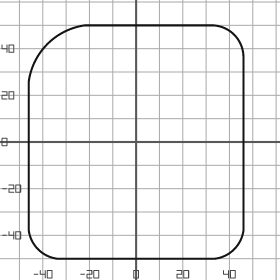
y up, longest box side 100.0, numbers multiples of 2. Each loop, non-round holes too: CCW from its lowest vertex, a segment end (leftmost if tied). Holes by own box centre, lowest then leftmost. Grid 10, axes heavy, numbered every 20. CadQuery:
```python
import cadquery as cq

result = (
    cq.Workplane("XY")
    .moveTo(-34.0, -50.0)
    .lineTo(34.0, -50.0)
    .threePointArc((42.0, -46.0), (46.0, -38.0))
    .lineTo(46.0, 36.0)
    .threePointArc((42.0, 46.0), (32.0, 50.0))
    .lineTo(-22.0, 50.0)
    .threePointArc((-38.0, 42.0), (-46.0, 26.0))
    .lineTo(-46.0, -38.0)
    .threePointArc((-42.0, -46.0), (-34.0, -50.0))
    .close()
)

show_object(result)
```